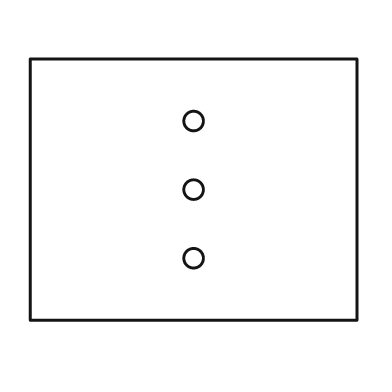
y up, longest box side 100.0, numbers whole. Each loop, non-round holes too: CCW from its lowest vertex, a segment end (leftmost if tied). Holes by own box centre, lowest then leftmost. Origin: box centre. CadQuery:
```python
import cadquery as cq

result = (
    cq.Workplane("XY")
    .moveTo(-50.0, -40.0)
    .lineTo(50.0, -40.0)
    .lineTo(50.0, 40.0)
    .lineTo(-50.0, 40.0)
    .close()
    .moveTo(0.0, -21.0)
    .circle(3.0)
    .moveTo(0.0, 0.0)
    .circle(3.0)
    .moveTo(0.0, 21.0)
    .circle(3.0)
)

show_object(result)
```